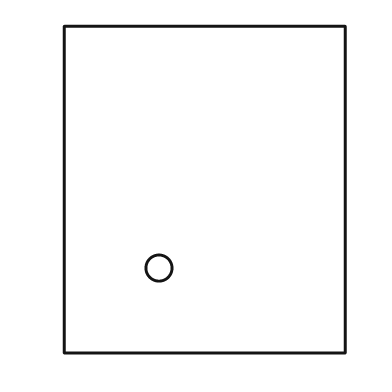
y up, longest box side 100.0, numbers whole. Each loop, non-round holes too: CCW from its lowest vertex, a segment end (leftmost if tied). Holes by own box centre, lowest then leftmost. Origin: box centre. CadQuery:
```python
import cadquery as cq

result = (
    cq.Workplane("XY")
    .moveTo(-43.0, -50.0)
    .lineTo(43.0, -50.0)
    .lineTo(43.0, 50.0)
    .lineTo(-43.0, 50.0)
    .close()
    .moveTo(-14.0, -24.0)
    .circle(4.0)
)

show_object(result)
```